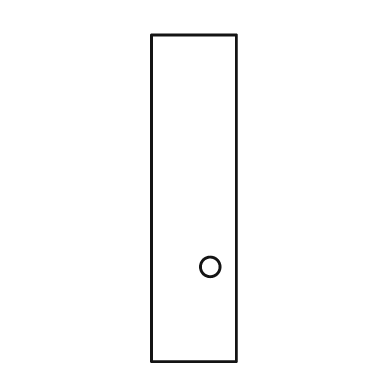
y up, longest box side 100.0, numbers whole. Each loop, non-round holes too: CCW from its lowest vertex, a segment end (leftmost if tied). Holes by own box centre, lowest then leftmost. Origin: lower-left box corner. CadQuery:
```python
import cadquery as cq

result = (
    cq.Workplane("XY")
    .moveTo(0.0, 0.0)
    .lineTo(26.0, 0.0)
    .lineTo(26.0, 100.0)
    .lineTo(0.0, 100.0)
    .close()
    .moveTo(18.0, 29.0)
    .circle(3.0)
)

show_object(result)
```